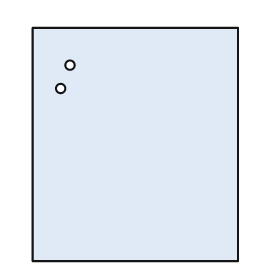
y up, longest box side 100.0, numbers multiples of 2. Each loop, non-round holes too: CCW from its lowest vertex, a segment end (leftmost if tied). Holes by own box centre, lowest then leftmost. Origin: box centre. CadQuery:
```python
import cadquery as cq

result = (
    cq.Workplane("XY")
    .moveTo(-44.0, -50.0)
    .lineTo(44.0, -50.0)
    .lineTo(44.0, 50.0)
    .lineTo(-44.0, 50.0)
    .close()
    .moveTo(-32.0, 24.0)
    .circle(2.0)
    .moveTo(-28.0, 34.0)
    .circle(2.0)
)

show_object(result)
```